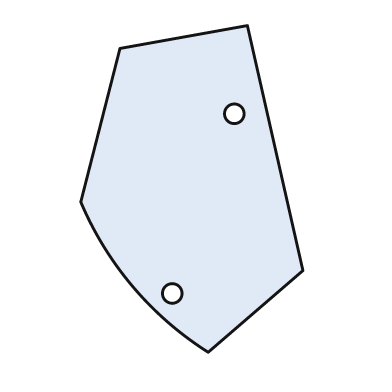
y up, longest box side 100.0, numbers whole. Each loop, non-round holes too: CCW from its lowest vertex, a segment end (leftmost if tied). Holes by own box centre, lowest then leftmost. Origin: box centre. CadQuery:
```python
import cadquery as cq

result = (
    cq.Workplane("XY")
    .moveTo(5.0, -50.0)
    .lineTo(34.0, -25.0)
    .lineTo(17.0, 50.0)
    .lineTo(-22.0, 43.0)
    .lineTo(-34.0, -4.0)
    .threePointArc((-18.0, -30.0), (5.0, -50.0))
    .close()
    .moveTo(-6.0, -32.0)
    .circle(3.0)
    .moveTo(13.0, 23.0)
    .circle(3.0)
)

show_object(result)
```